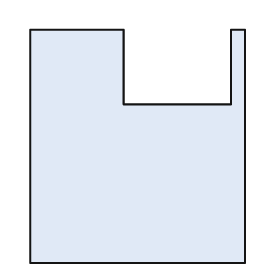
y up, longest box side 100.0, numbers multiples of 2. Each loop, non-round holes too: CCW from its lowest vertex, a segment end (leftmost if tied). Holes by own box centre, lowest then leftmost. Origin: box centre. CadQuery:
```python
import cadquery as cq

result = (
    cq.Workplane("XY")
    .moveTo(-46.0, -50.0)
    .lineTo(46.0, -50.0)
    .lineTo(46.0, 50.0)
    .lineTo(40.0, 50.0)
    .lineTo(40.0, 18.0)
    .lineTo(-6.0, 18.0)
    .lineTo(-6.0, 50.0)
    .lineTo(-46.0, 50.0)
    .close()
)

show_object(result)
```